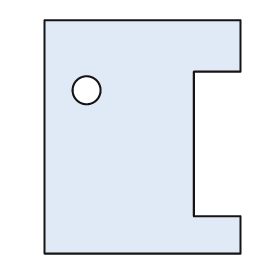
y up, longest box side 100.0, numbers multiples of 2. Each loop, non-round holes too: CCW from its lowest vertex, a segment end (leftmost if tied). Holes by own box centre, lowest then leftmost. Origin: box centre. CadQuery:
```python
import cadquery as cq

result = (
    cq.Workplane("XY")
    .moveTo(-42.0, -50.0)
    .lineTo(42.0, -50.0)
    .lineTo(42.0, -34.0)
    .lineTo(22.0, -34.0)
    .lineTo(22.0, 28.0)
    .lineTo(42.0, 28.0)
    .lineTo(42.0, 50.0)
    .lineTo(-42.0, 50.0)
    .close()
    .moveTo(-24.0, 20.0)
    .circle(6.0)
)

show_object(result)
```